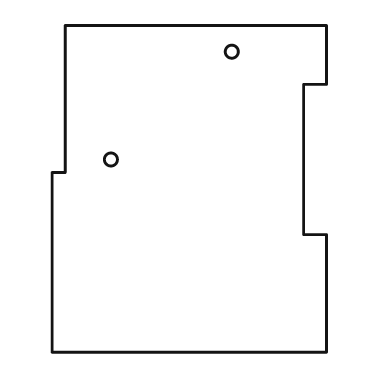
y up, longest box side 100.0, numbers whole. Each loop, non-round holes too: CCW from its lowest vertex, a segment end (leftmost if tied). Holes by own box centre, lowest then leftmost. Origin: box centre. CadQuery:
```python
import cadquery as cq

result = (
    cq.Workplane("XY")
    .moveTo(-42.0, -50.0)
    .lineTo(42.0, -50.0)
    .lineTo(42.0, -14.0)
    .lineTo(35.0, -14.0)
    .lineTo(35.0, 32.0)
    .lineTo(42.0, 32.0)
    .lineTo(42.0, 50.0)
    .lineTo(-38.0, 50.0)
    .lineTo(-38.0, 5.0)
    .lineTo(-42.0, 5.0)
    .close()
    .moveTo(-24.0, 9.0)
    .circle(2.0)
    .moveTo(13.0, 42.0)
    .circle(2.0)
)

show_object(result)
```